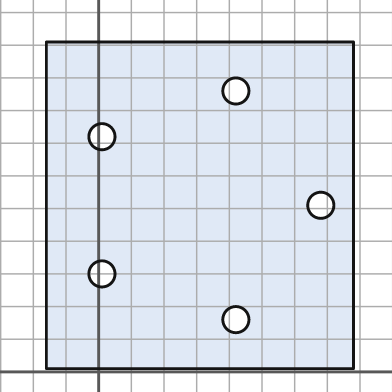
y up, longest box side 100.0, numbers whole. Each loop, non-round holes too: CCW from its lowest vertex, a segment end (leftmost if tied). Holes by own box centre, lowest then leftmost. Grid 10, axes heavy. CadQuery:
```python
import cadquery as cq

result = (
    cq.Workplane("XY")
    .moveTo(-16.0, 1.0)
    .lineTo(78.0, 1.0)
    .lineTo(78.0, 101.0)
    .lineTo(-16.0, 101.0)
    .close()
    .moveTo(42.0, 16.0)
    .circle(4.0)
    .moveTo(1.0, 30.0)
    .circle(4.0)
    .moveTo(68.0, 51.0)
    .circle(4.0)
    .moveTo(1.0, 72.0)
    .circle(4.0)
    .moveTo(42.0, 86.0)
    .circle(4.0)
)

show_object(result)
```